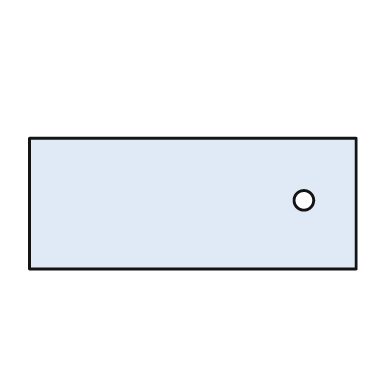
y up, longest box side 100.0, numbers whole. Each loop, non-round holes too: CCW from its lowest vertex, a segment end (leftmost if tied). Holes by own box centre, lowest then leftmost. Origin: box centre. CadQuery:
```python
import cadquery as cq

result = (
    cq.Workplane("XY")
    .moveTo(-50.0, -20.0)
    .lineTo(50.0, -20.0)
    .lineTo(50.0, 20.0)
    .lineTo(-50.0, 20.0)
    .close()
    .moveTo(34.0, 1.0)
    .circle(3.0)
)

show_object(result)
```